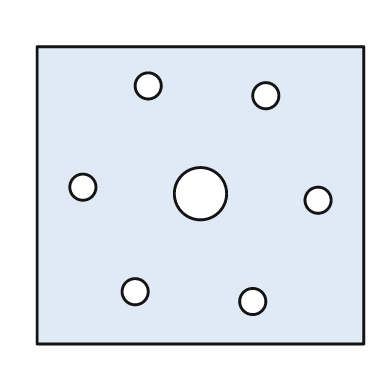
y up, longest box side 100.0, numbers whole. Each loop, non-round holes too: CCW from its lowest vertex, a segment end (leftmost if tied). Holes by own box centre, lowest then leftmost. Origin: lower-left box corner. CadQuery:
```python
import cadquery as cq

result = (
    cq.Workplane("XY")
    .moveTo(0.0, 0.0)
    .lineTo(100.0, 0.0)
    .lineTo(100.0, 91.0)
    .lineTo(0.0, 91.0)
    .close()
    .moveTo(66.0, 13.0)
    .circle(4.0)
    .moveTo(30.0, 16.0)
    .circle(4.0)
    .moveTo(86.0, 44.0)
    .circle(4.0)
    .moveTo(50.0, 46.0)
    .circle(8.0)
    .moveTo(14.0, 48.0)
    .circle(4.0)
    .moveTo(70.0, 76.0)
    .circle(4.0)
    .moveTo(34.0, 79.0)
    .circle(4.0)
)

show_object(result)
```